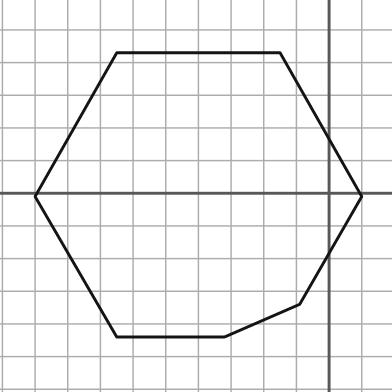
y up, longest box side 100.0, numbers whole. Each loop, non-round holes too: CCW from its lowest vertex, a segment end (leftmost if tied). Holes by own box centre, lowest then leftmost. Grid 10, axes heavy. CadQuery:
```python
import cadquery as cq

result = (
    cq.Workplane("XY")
    .moveTo(-65.0, -44.0)
    .lineTo(-32.0, -44.0)
    .lineTo(-9.0, -34.0)
    .lineTo(10.0, -1.0)
    .lineTo(-15.0, 43.0)
    .lineTo(-65.0, 43.0)
    .lineTo(-90.0, -1.0)
    .close()
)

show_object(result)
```